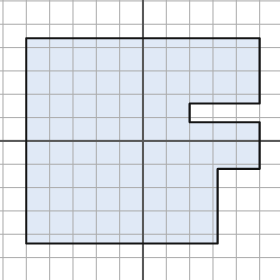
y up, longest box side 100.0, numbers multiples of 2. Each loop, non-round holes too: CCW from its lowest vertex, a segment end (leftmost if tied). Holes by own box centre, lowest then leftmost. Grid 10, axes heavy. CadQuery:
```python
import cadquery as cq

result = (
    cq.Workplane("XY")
    .moveTo(-50.0, -44.0)
    .lineTo(32.0, -44.0)
    .lineTo(32.0, -12.0)
    .lineTo(50.0, -12.0)
    .lineTo(50.0, 8.0)
    .lineTo(20.0, 8.0)
    .lineTo(20.0, 16.0)
    .lineTo(50.0, 16.0)
    .lineTo(50.0, 44.0)
    .lineTo(-50.0, 44.0)
    .close()
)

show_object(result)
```